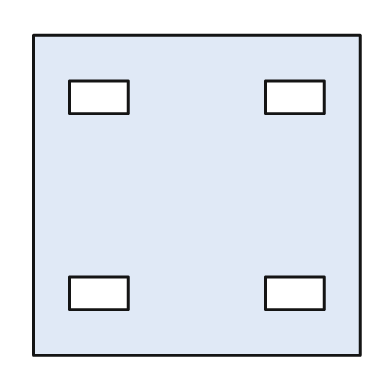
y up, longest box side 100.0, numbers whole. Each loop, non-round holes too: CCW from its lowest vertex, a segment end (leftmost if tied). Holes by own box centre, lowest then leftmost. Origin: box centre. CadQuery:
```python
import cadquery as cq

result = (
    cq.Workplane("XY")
    .moveTo(-50.0, -49.0)
    .lineTo(50.0, -49.0)
    .lineTo(50.0, 49.0)
    .lineTo(-50.0, 49.0)
    .close()
    .moveTo(-39.0, -35.0)
    .lineTo(-21.0, -35.0)
    .lineTo(-21.0, -25.0)
    .lineTo(-39.0, -25.0)
    .close()
    .moveTo(21.0, -35.0)
    .lineTo(39.0, -35.0)
    .lineTo(39.0, -25.0)
    .lineTo(21.0, -25.0)
    .close()
    .moveTo(-39.0, 25.0)
    .lineTo(-21.0, 25.0)
    .lineTo(-21.0, 35.0)
    .lineTo(-39.0, 35.0)
    .close()
    .moveTo(21.0, 25.0)
    .lineTo(39.0, 25.0)
    .lineTo(39.0, 35.0)
    .lineTo(21.0, 35.0)
    .close()
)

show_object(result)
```